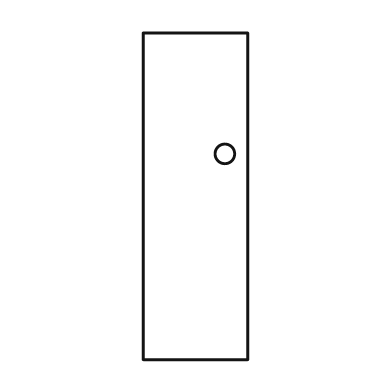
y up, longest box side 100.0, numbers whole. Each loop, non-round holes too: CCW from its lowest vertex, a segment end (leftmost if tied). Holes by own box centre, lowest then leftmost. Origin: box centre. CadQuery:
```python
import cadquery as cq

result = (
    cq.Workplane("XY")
    .moveTo(-16.0, -50.0)
    .lineTo(16.0, -50.0)
    .lineTo(16.0, 50.0)
    .lineTo(-16.0, 50.0)
    .close()
    .moveTo(9.0, 13.0)
    .circle(3.0)
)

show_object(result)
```